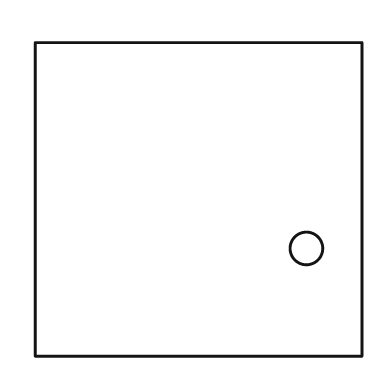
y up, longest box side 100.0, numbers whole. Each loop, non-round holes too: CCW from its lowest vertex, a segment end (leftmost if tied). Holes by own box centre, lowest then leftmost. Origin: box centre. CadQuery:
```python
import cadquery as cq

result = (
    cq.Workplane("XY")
    .moveTo(-50.0, -48.0)
    .lineTo(50.0, -48.0)
    .lineTo(50.0, 48.0)
    .lineTo(-50.0, 48.0)
    .close()
    .moveTo(33.0, -15.0)
    .circle(5.0)
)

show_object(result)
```